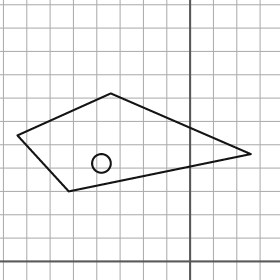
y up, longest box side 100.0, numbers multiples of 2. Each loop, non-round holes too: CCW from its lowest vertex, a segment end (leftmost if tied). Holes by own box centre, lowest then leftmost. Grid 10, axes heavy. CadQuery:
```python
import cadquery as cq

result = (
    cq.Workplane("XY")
    .moveTo(-52.0, 30.0)
    .lineTo(26.0, 46.0)
    .lineTo(-34.0, 72.0)
    .lineTo(-74.0, 54.0)
    .close()
    .moveTo(-38.0, 42.0)
    .circle(4.0)
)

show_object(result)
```